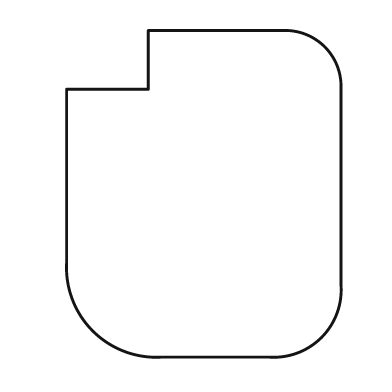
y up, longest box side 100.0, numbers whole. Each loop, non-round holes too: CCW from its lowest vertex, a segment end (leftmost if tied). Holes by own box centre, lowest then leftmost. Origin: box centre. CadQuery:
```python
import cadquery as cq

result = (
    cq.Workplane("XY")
    .moveTo(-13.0, -50.0)
    .lineTo(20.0, -50.0)
    .threePointArc((36.0, -44.0), (42.0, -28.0))
    .lineTo(42.0, 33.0)
    .threePointArc((37.0, 45.0), (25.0, 50.0))
    .lineTo(-17.0, 50.0)
    .lineTo(-17.0, 32.0)
    .lineTo(-42.0, 32.0)
    .lineTo(-42.0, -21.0)
    .threePointArc((-34.0, -42.0), (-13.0, -50.0))
    .close()
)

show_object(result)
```